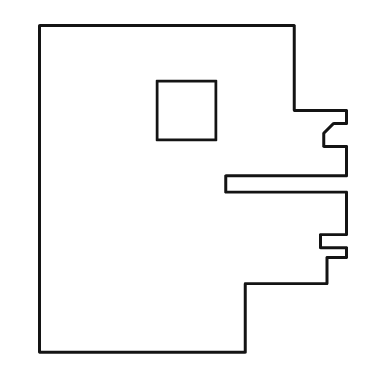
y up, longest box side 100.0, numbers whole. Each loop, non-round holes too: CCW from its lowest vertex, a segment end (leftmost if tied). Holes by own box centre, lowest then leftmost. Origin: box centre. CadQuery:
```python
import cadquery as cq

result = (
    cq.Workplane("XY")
    .moveTo(-47.0, -50.0)
    .lineTo(16.0, -50.0)
    .lineTo(16.0, -29.0)
    .lineTo(41.0, -29.0)
    .lineTo(41.0, -21.0)
    .lineTo(47.0, -21.0)
    .lineTo(47.0, -18.0)
    .lineTo(39.0, -18.0)
    .lineTo(39.0, -14.0)
    .lineTo(47.0, -14.0)
    .lineTo(47.0, -1.0)
    .lineTo(10.0, -1.0)
    .lineTo(10.0, 4.0)
    .lineTo(47.0, 4.0)
    .lineTo(47.0, 13.0)
    .lineTo(40.0, 13.0)
    .lineTo(40.0, 17.0)
    .lineTo(43.0, 20.0)
    .lineTo(47.0, 20.0)
    .lineTo(47.0, 24.0)
    .lineTo(31.0, 24.0)
    .lineTo(31.0, 50.0)
    .lineTo(-47.0, 50.0)
    .close()
    .moveTo(-11.0, 15.0)
    .lineTo(7.0, 15.0)
    .lineTo(7.0, 33.0)
    .lineTo(-11.0, 33.0)
    .close()
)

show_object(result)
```